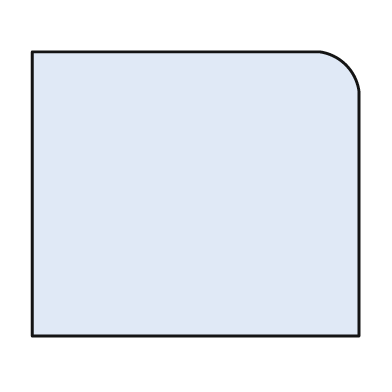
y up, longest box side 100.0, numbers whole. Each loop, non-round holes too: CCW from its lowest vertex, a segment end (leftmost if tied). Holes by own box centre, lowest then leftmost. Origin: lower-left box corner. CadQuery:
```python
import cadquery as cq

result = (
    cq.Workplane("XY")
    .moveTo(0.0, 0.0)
    .lineTo(100.0, 0.0)
    .lineTo(100.0, 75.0)
    .threePointArc((96.0, 83.0), (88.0, 87.0))
    .lineTo(0.0, 87.0)
    .close()
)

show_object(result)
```